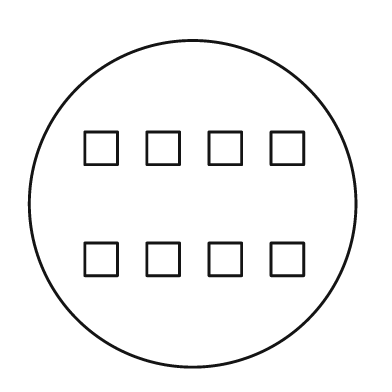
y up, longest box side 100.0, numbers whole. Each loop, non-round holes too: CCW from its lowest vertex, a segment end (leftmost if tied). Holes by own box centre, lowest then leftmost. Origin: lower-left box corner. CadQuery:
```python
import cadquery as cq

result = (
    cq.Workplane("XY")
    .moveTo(50.0, 50.0)
    .circle(50.0)
    .moveTo(17.0, 28.0)
    .lineTo(27.0, 28.0)
    .lineTo(27.0, 38.0)
    .lineTo(17.0, 38.0)
    .close()
    .moveTo(36.0, 28.0)
    .lineTo(46.0, 28.0)
    .lineTo(46.0, 38.0)
    .lineTo(36.0, 38.0)
    .close()
    .moveTo(55.0, 28.0)
    .lineTo(65.0, 28.0)
    .lineTo(65.0, 38.0)
    .lineTo(55.0, 38.0)
    .close()
    .moveTo(74.0, 28.0)
    .lineTo(84.0, 28.0)
    .lineTo(84.0, 38.0)
    .lineTo(74.0, 38.0)
    .close()
    .moveTo(17.0, 62.0)
    .lineTo(27.0, 62.0)
    .lineTo(27.0, 72.0)
    .lineTo(17.0, 72.0)
    .close()
    .moveTo(36.0, 62.0)
    .lineTo(46.0, 62.0)
    .lineTo(46.0, 72.0)
    .lineTo(36.0, 72.0)
    .close()
    .moveTo(55.0, 62.0)
    .lineTo(65.0, 62.0)
    .lineTo(65.0, 72.0)
    .lineTo(55.0, 72.0)
    .close()
    .moveTo(74.0, 62.0)
    .lineTo(84.0, 62.0)
    .lineTo(84.0, 72.0)
    .lineTo(74.0, 72.0)
    .close()
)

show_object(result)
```